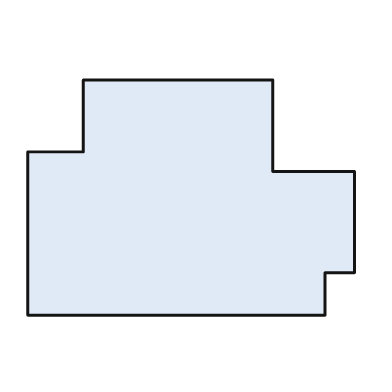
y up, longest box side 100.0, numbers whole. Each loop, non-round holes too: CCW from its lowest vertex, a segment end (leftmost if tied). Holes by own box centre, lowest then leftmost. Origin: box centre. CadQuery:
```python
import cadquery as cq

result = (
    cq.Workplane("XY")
    .moveTo(-50.0, -36.0)
    .lineTo(41.0, -36.0)
    .lineTo(41.0, -23.0)
    .lineTo(50.0, -23.0)
    .lineTo(50.0, 8.0)
    .lineTo(25.0, 8.0)
    .lineTo(25.0, 36.0)
    .lineTo(-33.0, 36.0)
    .lineTo(-33.0, 14.0)
    .lineTo(-50.0, 14.0)
    .close()
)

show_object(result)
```